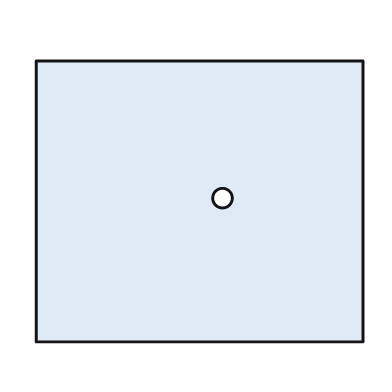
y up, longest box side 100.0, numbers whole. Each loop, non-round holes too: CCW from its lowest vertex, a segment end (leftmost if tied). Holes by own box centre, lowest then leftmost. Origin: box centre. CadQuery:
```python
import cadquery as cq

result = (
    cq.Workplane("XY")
    .moveTo(-50.0, -43.0)
    .lineTo(50.0, -43.0)
    .lineTo(50.0, 43.0)
    .lineTo(-50.0, 43.0)
    .close()
    .moveTo(7.0, 1.0)
    .circle(3.0)
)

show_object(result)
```